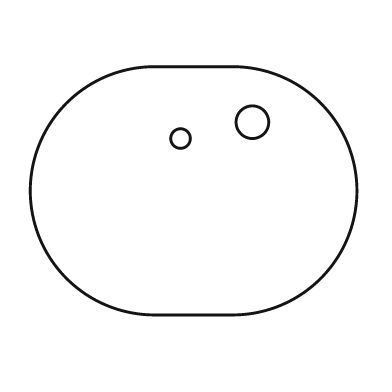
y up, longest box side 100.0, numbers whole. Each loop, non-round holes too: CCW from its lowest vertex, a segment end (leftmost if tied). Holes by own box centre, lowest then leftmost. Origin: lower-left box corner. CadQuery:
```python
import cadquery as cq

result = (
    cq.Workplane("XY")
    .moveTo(38.0, 0.0)
    .lineTo(62.0, 0.0)
    .threePointArc((100.0, 38.0), (62.0, 76.0))
    .lineTo(38.0, 76.0)
    .threePointArc((0.0, 38.0), (38.0, 0.0))
    .close()
    .moveTo(46.0, 54.0)
    .circle(3.0)
    .moveTo(68.0, 59.0)
    .circle(5.0)
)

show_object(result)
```